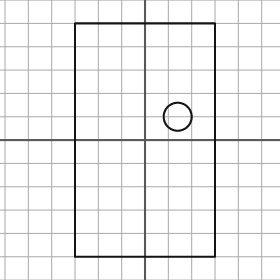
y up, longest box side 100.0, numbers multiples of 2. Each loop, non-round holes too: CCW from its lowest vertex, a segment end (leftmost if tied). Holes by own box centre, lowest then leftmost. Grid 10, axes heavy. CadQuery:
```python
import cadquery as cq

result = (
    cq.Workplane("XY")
    .moveTo(-30.0, -50.0)
    .lineTo(30.0, -50.0)
    .lineTo(30.0, 50.0)
    .lineTo(-30.0, 50.0)
    .close()
    .moveTo(14.0, 10.0)
    .circle(6.0)
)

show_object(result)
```